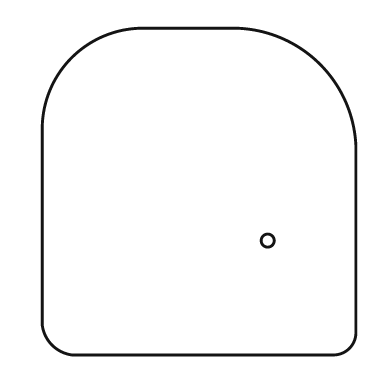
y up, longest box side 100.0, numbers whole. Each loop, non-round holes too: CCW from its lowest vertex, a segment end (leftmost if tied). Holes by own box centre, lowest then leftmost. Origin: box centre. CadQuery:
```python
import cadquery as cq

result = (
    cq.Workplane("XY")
    .moveTo(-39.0, -50.0)
    .lineTo(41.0, -50.0)
    .threePointArc((46.0, -48.0), (48.0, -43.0))
    .lineTo(48.0, 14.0)
    .threePointArc((37.0, 39.0), (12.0, 50.0))
    .lineTo(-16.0, 50.0)
    .threePointArc((-39.0, 41.0), (-48.0, 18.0))
    .lineTo(-48.0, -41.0)
    .threePointArc((-45.0, -47.0), (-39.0, -50.0))
    .close()
    .moveTo(21.0, -15.0)
    .circle(2.0)
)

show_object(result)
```